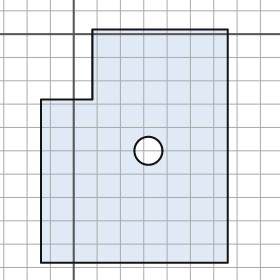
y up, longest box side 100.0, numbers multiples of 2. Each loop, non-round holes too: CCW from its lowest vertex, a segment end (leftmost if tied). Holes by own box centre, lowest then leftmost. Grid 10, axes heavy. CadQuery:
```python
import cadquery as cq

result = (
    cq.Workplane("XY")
    .moveTo(-14.0, -98.0)
    .lineTo(66.0, -98.0)
    .lineTo(66.0, 2.0)
    .lineTo(8.0, 2.0)
    .lineTo(8.0, -28.0)
    .lineTo(-14.0, -28.0)
    .close()
    .moveTo(32.0, -50.0)
    .circle(6.0)
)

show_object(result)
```